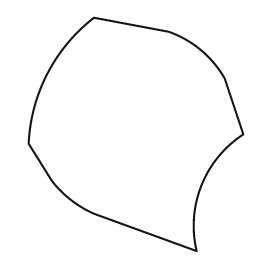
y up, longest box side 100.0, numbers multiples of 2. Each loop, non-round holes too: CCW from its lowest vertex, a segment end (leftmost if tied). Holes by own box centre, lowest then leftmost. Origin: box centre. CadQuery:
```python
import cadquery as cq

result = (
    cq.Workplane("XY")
    .moveTo(26.0, -50.0)
    .threePointArc((28.0, -22.0), (46.0, 0.0))
    .lineTo(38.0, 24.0)
    .threePointArc((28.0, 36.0), (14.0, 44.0))
    .lineTo(-18.0, 50.0)
    .threePointArc((-38.0, 26.0), (-46.0, -4.0))
    .lineTo(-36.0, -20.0)
    .threePointArc((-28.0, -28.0), (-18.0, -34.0))
    .close()
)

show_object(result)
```